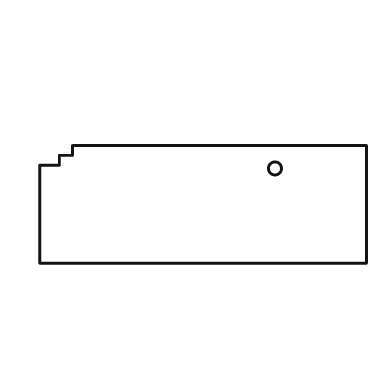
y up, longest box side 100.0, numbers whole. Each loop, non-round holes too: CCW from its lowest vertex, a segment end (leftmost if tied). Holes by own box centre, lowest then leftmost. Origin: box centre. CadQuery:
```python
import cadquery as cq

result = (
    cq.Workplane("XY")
    .moveTo(-50.0, -18.0)
    .lineTo(50.0, -18.0)
    .lineTo(50.0, 18.0)
    .lineTo(-40.0, 18.0)
    .lineTo(-40.0, 15.0)
    .lineTo(-44.0, 15.0)
    .lineTo(-44.0, 12.0)
    .lineTo(-50.0, 12.0)
    .close()
    .moveTo(22.0, 11.0)
    .circle(2.0)
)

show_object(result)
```